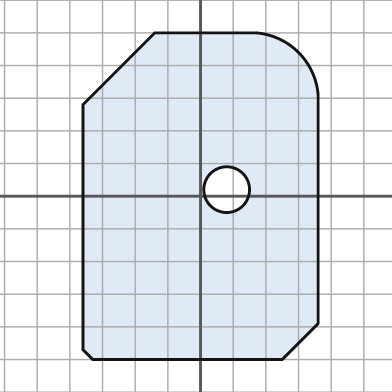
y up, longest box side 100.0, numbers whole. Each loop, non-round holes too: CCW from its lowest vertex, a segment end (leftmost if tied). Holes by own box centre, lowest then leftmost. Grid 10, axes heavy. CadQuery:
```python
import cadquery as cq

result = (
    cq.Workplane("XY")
    .moveTo(-33.0, -50.0)
    .lineTo(25.0, -50.0)
    .lineTo(36.0, -39.0)
    .lineTo(36.0, 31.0)
    .threePointArc((30.0, 44.0), (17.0, 50.0))
    .lineTo(-14.0, 50.0)
    .lineTo(-36.0, 28.0)
    .lineTo(-36.0, -47.0)
    .close()
    .moveTo(8.0, 2.0)
    .circle(7.0)
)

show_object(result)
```